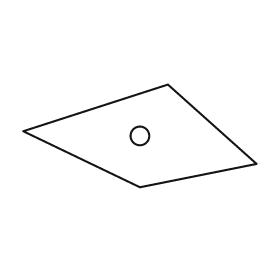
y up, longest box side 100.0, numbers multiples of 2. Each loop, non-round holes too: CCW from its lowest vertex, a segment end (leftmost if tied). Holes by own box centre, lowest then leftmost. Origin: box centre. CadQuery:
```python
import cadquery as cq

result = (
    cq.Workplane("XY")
    .moveTo(0.0, -22.0)
    .lineTo(50.0, -12.0)
    .lineTo(12.0, 22.0)
    .lineTo(-50.0, 2.0)
    .close()
    .moveTo(0.0, 0.0)
    .circle(4.0)
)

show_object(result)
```